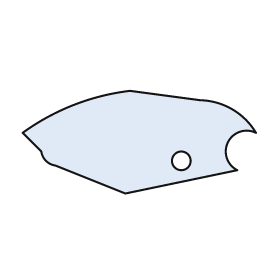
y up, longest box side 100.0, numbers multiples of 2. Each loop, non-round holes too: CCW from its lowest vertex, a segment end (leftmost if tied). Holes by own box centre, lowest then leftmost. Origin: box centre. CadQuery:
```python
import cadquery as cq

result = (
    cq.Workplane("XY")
    .moveTo(-6.0, -22.0)
    .lineTo(42.0, -12.0)
    .threePointArc((38.0, 0.0), (50.0, 4.0))
    .threePointArc((40.0, 14.0), (26.0, 18.0))
    .lineTo(-4.0, 22.0)
    .threePointArc((-28.0, 16.0), (-50.0, 4.0))
    .lineTo(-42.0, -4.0)
    .threePointArc((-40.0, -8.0), (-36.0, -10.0))
    .close()
    .moveTo(18.0, -8.0)
    .circle(4.0)
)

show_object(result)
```